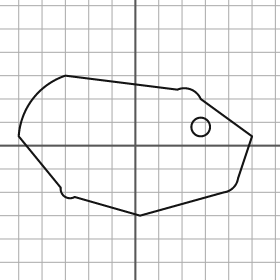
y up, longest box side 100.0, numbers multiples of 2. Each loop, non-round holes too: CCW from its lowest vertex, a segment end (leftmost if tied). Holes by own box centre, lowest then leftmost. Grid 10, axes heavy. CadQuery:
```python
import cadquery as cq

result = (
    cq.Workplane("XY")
    .moveTo(2.0, -30.0)
    .lineTo(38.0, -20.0)
    .threePointArc((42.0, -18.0), (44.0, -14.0))
    .lineTo(50.0, 4.0)
    .lineTo(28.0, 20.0)
    .threePointArc((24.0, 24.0), (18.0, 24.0))
    .lineTo(-30.0, 30.0)
    .threePointArc((-44.0, 20.0), (-50.0, 4.0))
    .lineTo(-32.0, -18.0)
    .threePointArc((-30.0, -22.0), (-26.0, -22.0))
    .close()
    .moveTo(28.0, 8.0)
    .circle(4.0)
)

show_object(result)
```